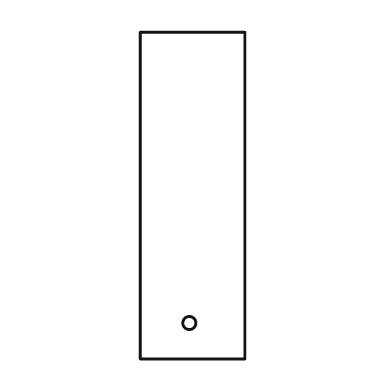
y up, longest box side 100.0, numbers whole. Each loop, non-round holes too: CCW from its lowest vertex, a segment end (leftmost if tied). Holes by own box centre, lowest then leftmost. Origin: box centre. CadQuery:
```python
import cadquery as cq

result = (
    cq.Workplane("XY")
    .moveTo(-16.0, -50.0)
    .lineTo(16.0, -50.0)
    .lineTo(16.0, 50.0)
    .lineTo(-16.0, 50.0)
    .close()
    .moveTo(-1.0, -39.0)
    .circle(2.0)
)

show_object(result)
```